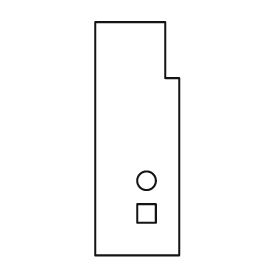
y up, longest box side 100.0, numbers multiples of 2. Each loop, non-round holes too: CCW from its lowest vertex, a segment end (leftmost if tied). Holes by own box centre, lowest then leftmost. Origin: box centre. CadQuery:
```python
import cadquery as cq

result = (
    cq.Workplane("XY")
    .moveTo(-18.0, -50.0)
    .lineTo(18.0, -50.0)
    .lineTo(18.0, 26.0)
    .lineTo(12.0, 26.0)
    .lineTo(12.0, 50.0)
    .lineTo(-18.0, 50.0)
    .close()
    .moveTo(0.0, -36.0)
    .lineTo(8.0, -36.0)
    .lineTo(8.0, -28.0)
    .lineTo(0.0, -28.0)
    .close()
    .moveTo(4.0, -18.0)
    .circle(4.0)
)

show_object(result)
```